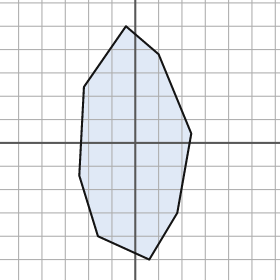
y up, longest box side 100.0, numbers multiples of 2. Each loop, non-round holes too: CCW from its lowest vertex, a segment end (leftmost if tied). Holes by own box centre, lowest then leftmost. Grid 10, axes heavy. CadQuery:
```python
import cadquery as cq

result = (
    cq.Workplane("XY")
    .moveTo(6.0, -50.0)
    .lineTo(18.0, -30.0)
    .lineTo(24.0, 4.0)
    .lineTo(10.0, 38.0)
    .lineTo(-4.0, 50.0)
    .lineTo(-22.0, 24.0)
    .lineTo(-24.0, -14.0)
    .lineTo(-16.0, -40.0)
    .close()
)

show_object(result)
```